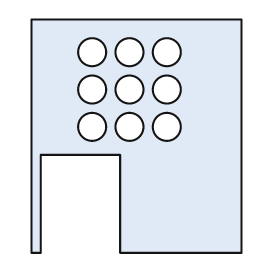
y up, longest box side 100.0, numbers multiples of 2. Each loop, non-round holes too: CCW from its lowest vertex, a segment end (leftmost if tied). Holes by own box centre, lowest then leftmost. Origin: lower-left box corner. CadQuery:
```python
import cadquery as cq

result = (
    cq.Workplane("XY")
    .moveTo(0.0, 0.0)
    .lineTo(4.0, 0.0)
    .lineTo(4.0, 42.0)
    .lineTo(38.0, 42.0)
    .lineTo(38.0, 0.0)
    .lineTo(90.0, 0.0)
    .lineTo(90.0, 100.0)
    .lineTo(0.0, 100.0)
    .close()
    .moveTo(26.0, 54.0)
    .circle(6.0)
    .moveTo(42.0, 54.0)
    .circle(6.0)
    .moveTo(58.0, 54.0)
    .circle(6.0)
    .moveTo(26.0, 70.0)
    .circle(6.0)
    .moveTo(42.0, 70.0)
    .circle(6.0)
    .moveTo(58.0, 70.0)
    .circle(6.0)
    .moveTo(26.0, 86.0)
    .circle(6.0)
    .moveTo(42.0, 86.0)
    .circle(6.0)
    .moveTo(58.0, 86.0)
    .circle(6.0)
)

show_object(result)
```